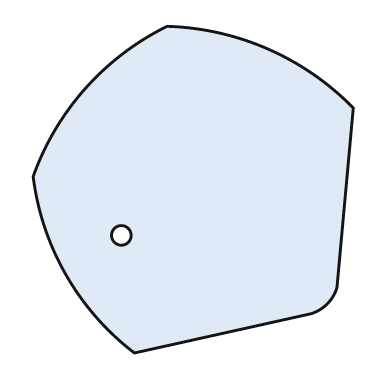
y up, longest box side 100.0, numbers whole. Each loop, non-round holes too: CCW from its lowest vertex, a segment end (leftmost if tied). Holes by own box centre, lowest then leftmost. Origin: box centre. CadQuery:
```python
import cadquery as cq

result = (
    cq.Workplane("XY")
    .moveTo(-18.0, -50.0)
    .lineTo(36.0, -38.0)
    .threePointArc((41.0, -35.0), (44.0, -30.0))
    .lineTo(49.0, 25.0)
    .threePointArc((23.0, 43.0), (-8.0, 50.0))
    .threePointArc((-33.0, 31.0), (-49.0, 4.0))
    .threePointArc((-39.0, -26.0), (-18.0, -50.0))
    .close()
    .moveTo(-22.0, -14.0)
    .circle(3.0)
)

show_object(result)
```